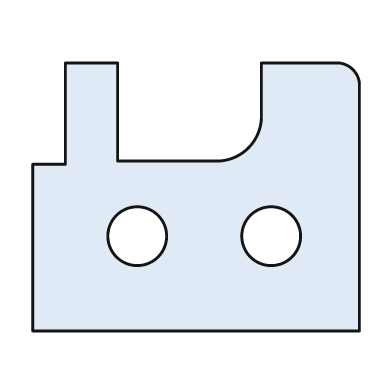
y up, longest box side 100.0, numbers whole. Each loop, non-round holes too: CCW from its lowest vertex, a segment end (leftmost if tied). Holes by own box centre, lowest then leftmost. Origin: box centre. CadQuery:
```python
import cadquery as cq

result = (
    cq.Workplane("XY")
    .moveTo(-50.0, -41.0)
    .lineTo(50.0, -41.0)
    .lineTo(50.0, 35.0)
    .threePointArc((48.0, 39.0), (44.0, 41.0))
    .lineTo(20.0, 41.0)
    .lineTo(20.0, 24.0)
    .threePointArc((16.0, 15.0), (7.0, 11.0))
    .lineTo(-24.0, 11.0)
    .lineTo(-24.0, 41.0)
    .lineTo(-40.0, 41.0)
    .lineTo(-40.0, 10.0)
    .lineTo(-50.0, 10.0)
    .close()
    .moveTo(-18.0, -12.0)
    .circle(9.0)
    .moveTo(23.0, -12.0)
    .circle(9.0)
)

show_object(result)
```